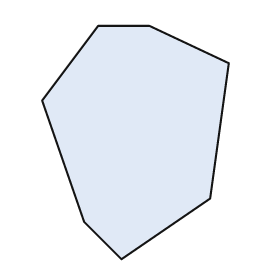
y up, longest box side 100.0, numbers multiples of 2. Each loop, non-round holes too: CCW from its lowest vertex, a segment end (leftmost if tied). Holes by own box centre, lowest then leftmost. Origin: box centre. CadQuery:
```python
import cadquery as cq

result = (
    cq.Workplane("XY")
    .moveTo(-6.0, -50.0)
    .lineTo(32.0, -24.0)
    .lineTo(40.0, 34.0)
    .lineTo(6.0, 50.0)
    .lineTo(-16.0, 50.0)
    .lineTo(-40.0, 18.0)
    .lineTo(-22.0, -34.0)
    .close()
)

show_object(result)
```